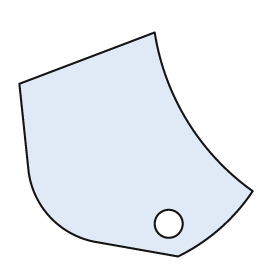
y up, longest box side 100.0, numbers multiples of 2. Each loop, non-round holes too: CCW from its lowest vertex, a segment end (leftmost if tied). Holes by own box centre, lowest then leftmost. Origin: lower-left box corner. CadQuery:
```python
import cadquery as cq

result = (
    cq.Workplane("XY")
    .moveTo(68.0, 0.0)
    .threePointArc((86.0, 12.0), (100.0, 28.0))
    .threePointArc((72.0, 58.0), (58.0, 96.0))
    .lineTo(0.0, 74.0)
    .lineTo(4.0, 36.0)
    .threePointArc((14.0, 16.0), (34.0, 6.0))
    .close()
    .moveTo(64.0, 14.0)
    .circle(6.0)
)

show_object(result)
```